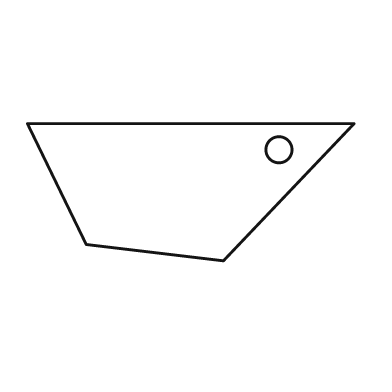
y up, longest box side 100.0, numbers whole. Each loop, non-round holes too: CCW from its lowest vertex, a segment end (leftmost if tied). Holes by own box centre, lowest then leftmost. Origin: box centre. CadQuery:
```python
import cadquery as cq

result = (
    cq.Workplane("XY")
    .moveTo(10.0, -21.0)
    .lineTo(50.0, 21.0)
    .lineTo(-50.0, 21.0)
    .lineTo(-32.0, -16.0)
    .close()
    .moveTo(27.0, 13.0)
    .circle(4.0)
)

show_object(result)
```